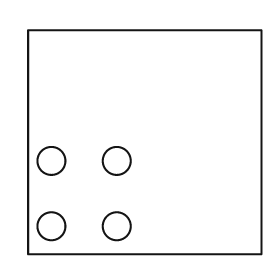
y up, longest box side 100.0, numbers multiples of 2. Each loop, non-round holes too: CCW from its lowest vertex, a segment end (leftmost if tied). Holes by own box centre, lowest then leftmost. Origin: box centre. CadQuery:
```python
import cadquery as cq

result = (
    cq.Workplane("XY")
    .moveTo(-50.0, -48.0)
    .lineTo(50.0, -48.0)
    .lineTo(50.0, 48.0)
    .lineTo(-50.0, 48.0)
    .close()
    .moveTo(-40.0, -36.0)
    .circle(6.0)
    .moveTo(-12.0, -36.0)
    .circle(6.0)
    .moveTo(-40.0, -8.0)
    .circle(6.0)
    .moveTo(-12.0, -8.0)
    .circle(6.0)
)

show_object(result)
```